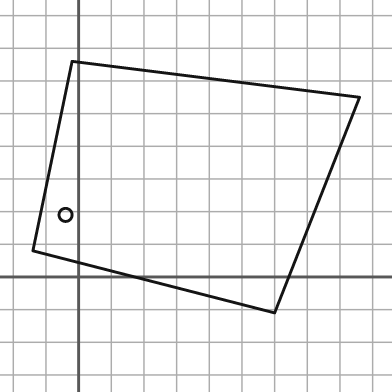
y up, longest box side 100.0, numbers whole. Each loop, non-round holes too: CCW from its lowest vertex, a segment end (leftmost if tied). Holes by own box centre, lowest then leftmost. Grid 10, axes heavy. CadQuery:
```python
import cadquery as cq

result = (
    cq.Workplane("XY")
    .moveTo(60.0, -11.0)
    .lineTo(86.0, 55.0)
    .lineTo(-2.0, 66.0)
    .lineTo(-14.0, 8.0)
    .close()
    .moveTo(-4.0, 19.0)
    .circle(2.0)
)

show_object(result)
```